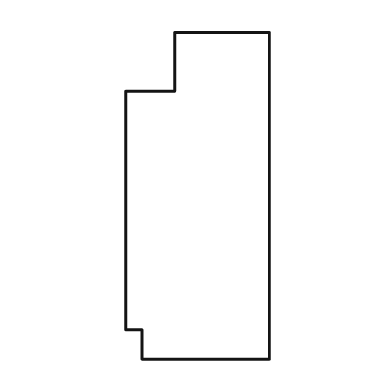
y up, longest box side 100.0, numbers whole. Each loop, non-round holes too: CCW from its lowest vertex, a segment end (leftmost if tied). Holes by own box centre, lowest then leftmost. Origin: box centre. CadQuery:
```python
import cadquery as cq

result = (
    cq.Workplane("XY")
    .moveTo(-17.0, -50.0)
    .lineTo(22.0, -50.0)
    .lineTo(22.0, 50.0)
    .lineTo(-7.0, 50.0)
    .lineTo(-7.0, 32.0)
    .lineTo(-22.0, 32.0)
    .lineTo(-22.0, -41.0)
    .lineTo(-17.0, -41.0)
    .close()
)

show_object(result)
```